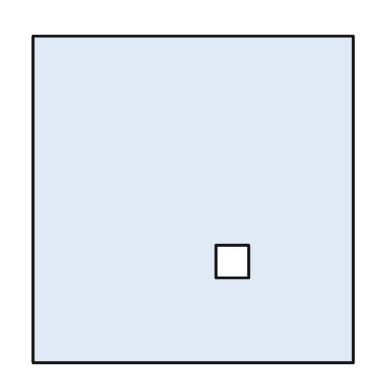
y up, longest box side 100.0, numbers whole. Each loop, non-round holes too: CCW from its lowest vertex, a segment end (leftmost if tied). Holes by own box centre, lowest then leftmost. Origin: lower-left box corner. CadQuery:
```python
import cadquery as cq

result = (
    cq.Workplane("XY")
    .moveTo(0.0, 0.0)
    .lineTo(98.0, 0.0)
    .lineTo(98.0, 100.0)
    .lineTo(0.0, 100.0)
    .close()
    .moveTo(56.0, 26.0)
    .lineTo(66.0, 26.0)
    .lineTo(66.0, 36.0)
    .lineTo(56.0, 36.0)
    .close()
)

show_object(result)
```